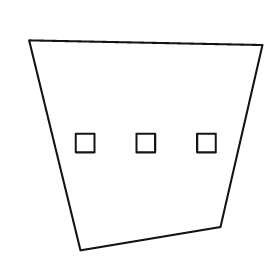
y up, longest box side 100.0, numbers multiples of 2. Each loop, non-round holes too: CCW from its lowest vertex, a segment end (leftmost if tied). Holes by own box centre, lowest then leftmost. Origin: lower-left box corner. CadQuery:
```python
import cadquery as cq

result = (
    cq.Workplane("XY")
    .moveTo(22.0, 0.0)
    .lineTo(82.0, 10.0)
    .lineTo(100.0, 88.0)
    .lineTo(0.0, 90.0)
    .close()
    .moveTo(20.0, 42.0)
    .lineTo(28.0, 42.0)
    .lineTo(28.0, 50.0)
    .lineTo(20.0, 50.0)
    .close()
    .moveTo(46.0, 42.0)
    .lineTo(54.0, 42.0)
    .lineTo(54.0, 50.0)
    .lineTo(46.0, 50.0)
    .close()
    .moveTo(72.0, 42.0)
    .lineTo(80.0, 42.0)
    .lineTo(80.0, 50.0)
    .lineTo(72.0, 50.0)
    .close()
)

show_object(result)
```